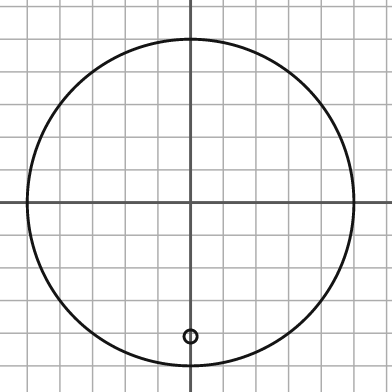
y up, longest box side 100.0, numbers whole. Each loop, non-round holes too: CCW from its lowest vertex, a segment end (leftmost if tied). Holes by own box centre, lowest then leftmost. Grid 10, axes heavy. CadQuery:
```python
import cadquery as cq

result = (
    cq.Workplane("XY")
    .moveTo(0.0, 0.0)
    .circle(50.0)
    .moveTo(0.0, -41.0)
    .circle(2.0)
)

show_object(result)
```